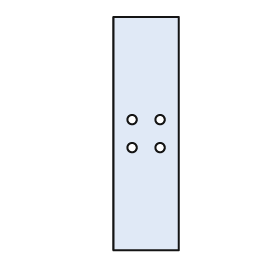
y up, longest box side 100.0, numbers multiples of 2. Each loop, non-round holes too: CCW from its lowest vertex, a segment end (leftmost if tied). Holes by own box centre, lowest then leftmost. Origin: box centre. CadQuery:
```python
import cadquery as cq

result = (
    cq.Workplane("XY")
    .moveTo(-14.0, -50.0)
    .lineTo(14.0, -50.0)
    .lineTo(14.0, 50.0)
    .lineTo(-14.0, 50.0)
    .close()
    .moveTo(-6.0, -6.0)
    .circle(2.0)
    .moveTo(6.0, -6.0)
    .circle(2.0)
    .moveTo(-6.0, 6.0)
    .circle(2.0)
    .moveTo(6.0, 6.0)
    .circle(2.0)
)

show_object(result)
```